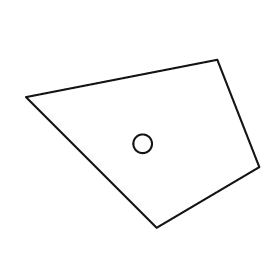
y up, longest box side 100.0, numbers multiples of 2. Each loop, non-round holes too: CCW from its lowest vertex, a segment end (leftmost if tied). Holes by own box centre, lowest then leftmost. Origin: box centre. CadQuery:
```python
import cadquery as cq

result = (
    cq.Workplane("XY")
    .moveTo(6.0, -36.0)
    .lineTo(50.0, -10.0)
    .lineTo(32.0, 36.0)
    .lineTo(-50.0, 20.0)
    .close()
    .moveTo(0.0, 0.0)
    .circle(4.0)
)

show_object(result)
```